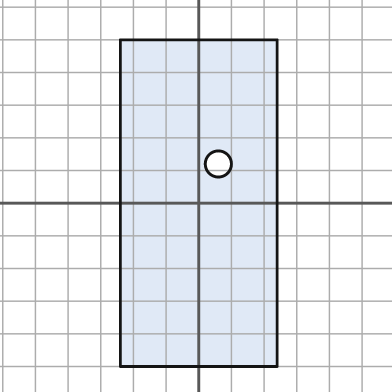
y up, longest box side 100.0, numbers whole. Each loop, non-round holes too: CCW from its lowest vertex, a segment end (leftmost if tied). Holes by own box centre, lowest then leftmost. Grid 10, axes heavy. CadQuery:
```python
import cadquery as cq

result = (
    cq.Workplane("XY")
    .moveTo(-24.0, -50.0)
    .lineTo(24.0, -50.0)
    .lineTo(24.0, 50.0)
    .lineTo(-24.0, 50.0)
    .close()
    .moveTo(6.0, 12.0)
    .circle(4.0)
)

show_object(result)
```